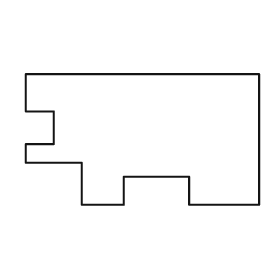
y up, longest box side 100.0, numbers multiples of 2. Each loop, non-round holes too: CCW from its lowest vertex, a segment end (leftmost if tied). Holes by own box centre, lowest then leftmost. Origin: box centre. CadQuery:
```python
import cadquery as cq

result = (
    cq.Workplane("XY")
    .moveTo(-26.0, -28.0)
    .lineTo(-8.0, -28.0)
    .lineTo(-8.0, -16.0)
    .lineTo(20.0, -16.0)
    .lineTo(20.0, -28.0)
    .lineTo(50.0, -28.0)
    .lineTo(50.0, 28.0)
    .lineTo(-50.0, 28.0)
    .lineTo(-50.0, 12.0)
    .lineTo(-38.0, 12.0)
    .lineTo(-38.0, -2.0)
    .lineTo(-50.0, -2.0)
    .lineTo(-50.0, -10.0)
    .lineTo(-26.0, -10.0)
    .close()
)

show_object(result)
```